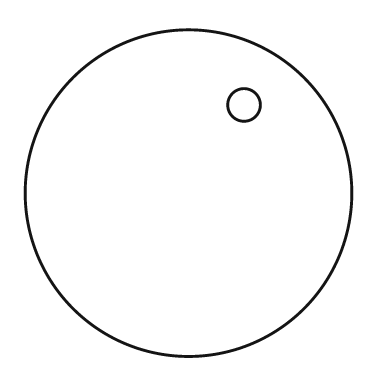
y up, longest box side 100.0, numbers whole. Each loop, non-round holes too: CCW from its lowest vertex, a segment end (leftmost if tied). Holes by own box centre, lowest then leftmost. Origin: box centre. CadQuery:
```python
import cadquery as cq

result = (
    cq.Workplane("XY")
    .moveTo(0.0, 0.0)
    .circle(50.0)
    .moveTo(17.0, 27.0)
    .circle(5.0)
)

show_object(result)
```